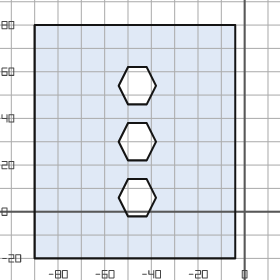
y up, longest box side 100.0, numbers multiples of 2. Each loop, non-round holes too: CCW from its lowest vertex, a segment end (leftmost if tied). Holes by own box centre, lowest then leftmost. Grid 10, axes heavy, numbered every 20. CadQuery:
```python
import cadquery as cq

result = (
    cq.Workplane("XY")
    .moveTo(-90.0, -20.0)
    .lineTo(-4.0, -20.0)
    .lineTo(-4.0, 80.0)
    .lineTo(-90.0, 80.0)
    .close()
    .moveTo(-50.0, -2.0)
    .lineTo(-42.0, -2.0)
    .lineTo(-38.0, 6.0)
    .lineTo(-42.0, 14.0)
    .lineTo(-50.0, 14.0)
    .lineTo(-54.0, 6.0)
    .close()
    .moveTo(-50.0, 22.0)
    .lineTo(-42.0, 22.0)
    .lineTo(-38.0, 30.0)
    .lineTo(-42.0, 38.0)
    .lineTo(-50.0, 38.0)
    .lineTo(-54.0, 30.0)
    .close()
    .moveTo(-50.0, 46.0)
    .lineTo(-42.0, 46.0)
    .lineTo(-38.0, 54.0)
    .lineTo(-42.0, 62.0)
    .lineTo(-50.0, 62.0)
    .lineTo(-54.0, 54.0)
    .close()
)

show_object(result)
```